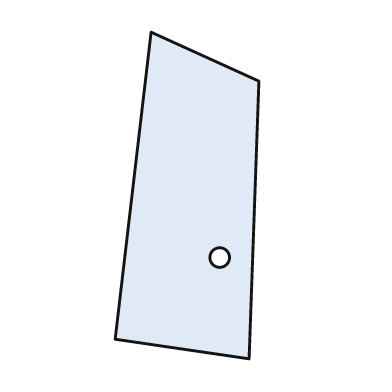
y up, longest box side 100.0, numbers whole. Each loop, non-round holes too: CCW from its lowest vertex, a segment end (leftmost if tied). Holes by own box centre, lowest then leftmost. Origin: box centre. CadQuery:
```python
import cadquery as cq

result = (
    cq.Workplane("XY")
    .moveTo(19.0, -50.0)
    .lineTo(22.0, 35.0)
    .lineTo(-11.0, 50.0)
    .lineTo(-22.0, -44.0)
    .close()
    .moveTo(10.0, -19.0)
    .circle(3.0)
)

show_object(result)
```